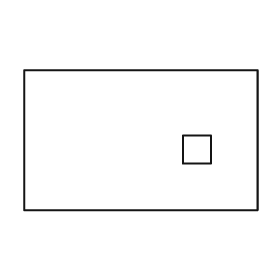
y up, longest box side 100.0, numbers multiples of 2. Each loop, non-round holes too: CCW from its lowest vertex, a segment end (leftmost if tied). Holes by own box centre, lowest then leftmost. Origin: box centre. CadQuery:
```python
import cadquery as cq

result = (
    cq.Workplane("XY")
    .moveTo(-50.0, -30.0)
    .lineTo(50.0, -30.0)
    .lineTo(50.0, 30.0)
    .lineTo(-50.0, 30.0)
    .close()
    .moveTo(18.0, -10.0)
    .lineTo(30.0, -10.0)
    .lineTo(30.0, 2.0)
    .lineTo(18.0, 2.0)
    .close()
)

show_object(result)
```